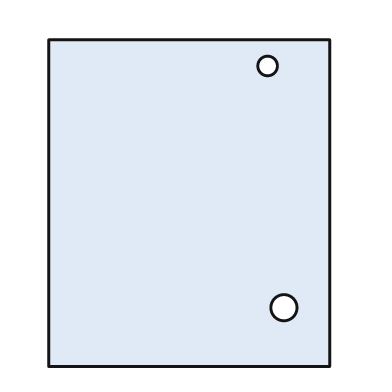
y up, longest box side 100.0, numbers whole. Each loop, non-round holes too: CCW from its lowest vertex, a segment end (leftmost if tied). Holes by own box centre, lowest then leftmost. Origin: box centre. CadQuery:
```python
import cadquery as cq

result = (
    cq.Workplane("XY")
    .moveTo(-43.0, -50.0)
    .lineTo(43.0, -50.0)
    .lineTo(43.0, 50.0)
    .lineTo(-43.0, 50.0)
    .close()
    .moveTo(29.0, -32.0)
    .circle(4.0)
    .moveTo(24.0, 42.0)
    .circle(3.0)
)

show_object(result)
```